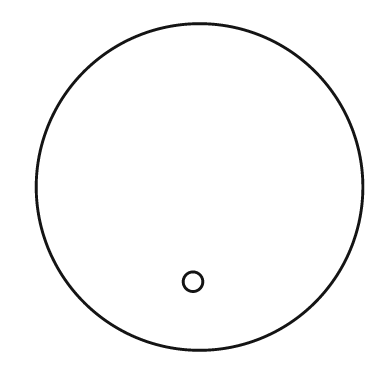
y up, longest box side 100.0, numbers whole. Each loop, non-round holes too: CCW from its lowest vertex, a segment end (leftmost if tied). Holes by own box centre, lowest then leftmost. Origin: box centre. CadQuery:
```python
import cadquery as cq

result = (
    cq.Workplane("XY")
    .moveTo(0.0, 0.0)
    .circle(50.0)
    .moveTo(-2.0, -29.0)
    .circle(3.0)
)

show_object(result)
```